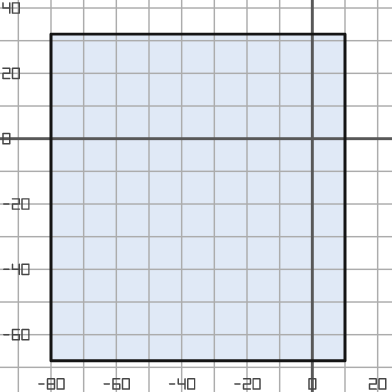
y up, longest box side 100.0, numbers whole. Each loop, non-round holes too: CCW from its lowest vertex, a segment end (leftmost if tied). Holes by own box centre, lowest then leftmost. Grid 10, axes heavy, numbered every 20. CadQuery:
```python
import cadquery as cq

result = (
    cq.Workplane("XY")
    .moveTo(-80.0, -68.0)
    .lineTo(10.0, -68.0)
    .lineTo(10.0, 32.0)
    .lineTo(-80.0, 32.0)
    .close()
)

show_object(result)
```